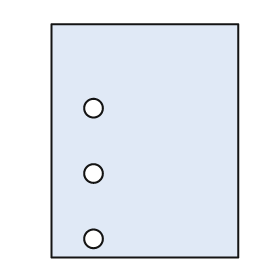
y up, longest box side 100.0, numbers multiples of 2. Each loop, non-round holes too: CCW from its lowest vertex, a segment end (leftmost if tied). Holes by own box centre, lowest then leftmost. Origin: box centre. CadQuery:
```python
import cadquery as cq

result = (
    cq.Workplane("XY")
    .moveTo(-40.0, -50.0)
    .lineTo(40.0, -50.0)
    .lineTo(40.0, 50.0)
    .lineTo(-40.0, 50.0)
    .close()
    .moveTo(-22.0, -42.0)
    .circle(4.0)
    .moveTo(-22.0, -14.0)
    .circle(4.0)
    .moveTo(-22.0, 14.0)
    .circle(4.0)
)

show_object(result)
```